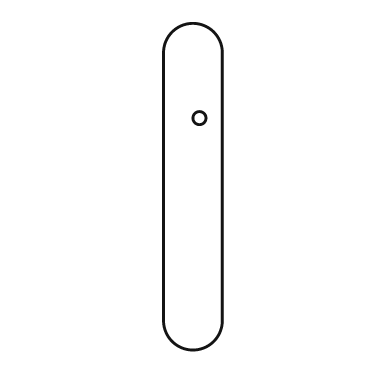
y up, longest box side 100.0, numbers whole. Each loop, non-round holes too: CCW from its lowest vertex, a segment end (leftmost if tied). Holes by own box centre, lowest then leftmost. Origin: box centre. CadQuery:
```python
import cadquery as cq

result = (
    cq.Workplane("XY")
    .moveTo(-9.0, -41.0)
    .threePointArc((0.0, -50.0), (9.0, -41.0))
    .lineTo(9.0, 41.0)
    .threePointArc((0.0, 50.0), (-9.0, 41.0))
    .close()
    .moveTo(2.0, 21.0)
    .circle(2.0)
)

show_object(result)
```